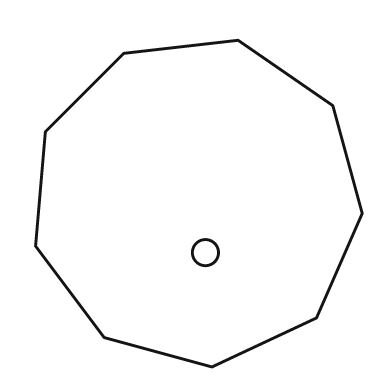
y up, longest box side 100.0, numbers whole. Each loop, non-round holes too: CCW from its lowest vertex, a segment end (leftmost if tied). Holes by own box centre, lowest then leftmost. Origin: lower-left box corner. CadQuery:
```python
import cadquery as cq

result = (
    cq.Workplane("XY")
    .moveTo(54.0, 0.0)
    .lineTo(86.0, 15.0)
    .lineTo(100.0, 47.0)
    .lineTo(91.0, 80.0)
    .lineTo(62.0, 100.0)
    .lineTo(27.0, 96.0)
    .lineTo(3.0, 72.0)
    .lineTo(0.0, 37.0)
    .lineTo(21.0, 9.0)
    .close()
    .moveTo(52.0, 35.0)
    .circle(4.0)
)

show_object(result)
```